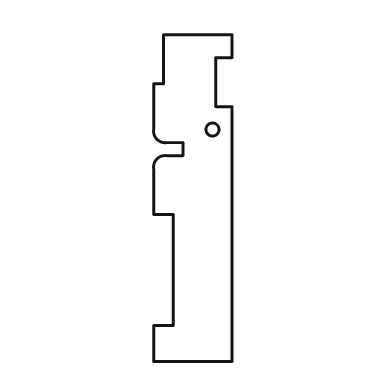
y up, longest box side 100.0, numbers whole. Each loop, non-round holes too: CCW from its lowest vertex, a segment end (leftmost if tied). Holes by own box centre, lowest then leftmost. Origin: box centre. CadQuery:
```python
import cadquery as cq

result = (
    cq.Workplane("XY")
    .moveTo(-12.0, -50.0)
    .lineTo(12.0, -50.0)
    .lineTo(12.0, 28.0)
    .lineTo(7.0, 28.0)
    .lineTo(7.0, 43.0)
    .lineTo(12.0, 43.0)
    .lineTo(12.0, 50.0)
    .lineTo(-9.0, 50.0)
    .lineTo(-9.0, 35.0)
    .lineTo(-12.0, 35.0)
    .lineTo(-12.0, 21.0)
    .threePointArc((-11.0, 18.0), (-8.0, 17.0))
    .lineTo(-3.0, 17.0)
    .lineTo(-3.0, 13.0)
    .lineTo(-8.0, 13.0)
    .threePointArc((-11.0, 12.0), (-12.0, 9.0))
    .lineTo(-12.0, -5.0)
    .lineTo(-6.0, -5.0)
    .lineTo(-6.0, -39.0)
    .lineTo(-12.0, -39.0)
    .close()
    .moveTo(6.0, 21.0)
    .circle(2.0)
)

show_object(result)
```